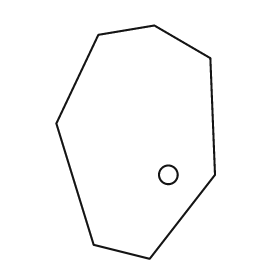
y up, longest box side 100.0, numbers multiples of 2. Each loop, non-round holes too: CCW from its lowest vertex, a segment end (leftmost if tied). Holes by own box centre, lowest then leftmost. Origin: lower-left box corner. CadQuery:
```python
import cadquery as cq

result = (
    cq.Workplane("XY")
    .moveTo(40.0, 0.0)
    .lineTo(68.0, 36.0)
    .lineTo(66.0, 86.0)
    .lineTo(42.0, 100.0)
    .lineTo(18.0, 96.0)
    .lineTo(0.0, 58.0)
    .lineTo(16.0, 6.0)
    .close()
    .moveTo(48.0, 36.0)
    .circle(4.0)
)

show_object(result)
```